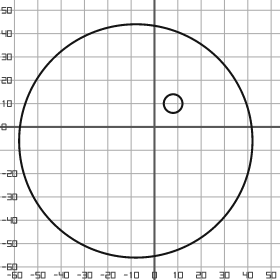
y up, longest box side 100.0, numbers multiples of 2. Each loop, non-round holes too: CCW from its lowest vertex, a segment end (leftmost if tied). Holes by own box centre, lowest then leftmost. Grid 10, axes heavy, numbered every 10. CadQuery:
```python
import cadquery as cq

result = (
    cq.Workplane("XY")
    .moveTo(-8.0, -6.0)
    .circle(50.0)
    .moveTo(8.0, 10.0)
    .circle(4.0)
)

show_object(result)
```